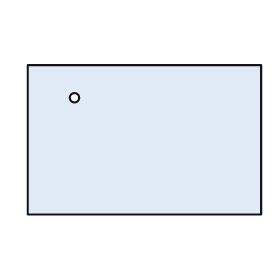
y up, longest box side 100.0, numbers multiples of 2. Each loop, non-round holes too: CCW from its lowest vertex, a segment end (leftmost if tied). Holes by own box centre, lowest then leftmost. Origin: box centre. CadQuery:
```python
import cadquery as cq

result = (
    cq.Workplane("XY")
    .moveTo(-50.0, -32.0)
    .lineTo(50.0, -32.0)
    .lineTo(50.0, 32.0)
    .lineTo(-50.0, 32.0)
    .close()
    .moveTo(-30.0, 18.0)
    .circle(2.0)
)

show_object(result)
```